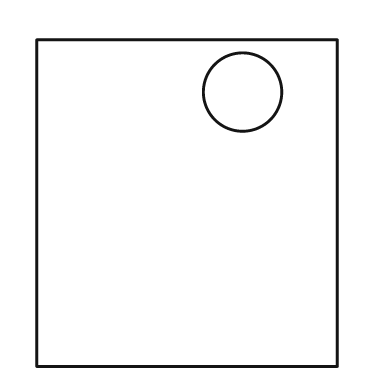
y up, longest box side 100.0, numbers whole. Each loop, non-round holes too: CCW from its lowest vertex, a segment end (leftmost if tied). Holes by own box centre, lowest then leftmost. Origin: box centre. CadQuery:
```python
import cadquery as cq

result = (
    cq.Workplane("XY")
    .moveTo(-46.0, -50.0)
    .lineTo(46.0, -50.0)
    .lineTo(46.0, 50.0)
    .lineTo(-46.0, 50.0)
    .close()
    .moveTo(17.0, 34.0)
    .circle(12.0)
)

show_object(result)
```